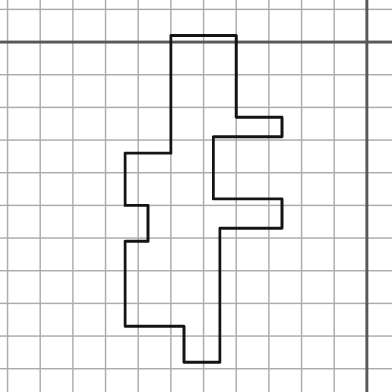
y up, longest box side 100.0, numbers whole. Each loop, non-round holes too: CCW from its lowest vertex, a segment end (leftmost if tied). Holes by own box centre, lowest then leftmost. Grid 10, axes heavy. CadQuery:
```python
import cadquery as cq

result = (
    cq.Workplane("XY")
    .moveTo(-56.0, -98.0)
    .lineTo(-45.0, -98.0)
    .lineTo(-45.0, -57.0)
    .lineTo(-26.0, -57.0)
    .lineTo(-26.0, -48.0)
    .lineTo(-47.0, -48.0)
    .lineTo(-47.0, -29.0)
    .lineTo(-26.0, -29.0)
    .lineTo(-26.0, -23.0)
    .lineTo(-40.0, -23.0)
    .lineTo(-40.0, 2.0)
    .lineTo(-60.0, 2.0)
    .lineTo(-60.0, -34.0)
    .lineTo(-74.0, -34.0)
    .lineTo(-74.0, -50.0)
    .lineTo(-67.0, -50.0)
    .lineTo(-67.0, -61.0)
    .lineTo(-74.0, -61.0)
    .lineTo(-74.0, -87.0)
    .lineTo(-56.0, -87.0)
    .close()
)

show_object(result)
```